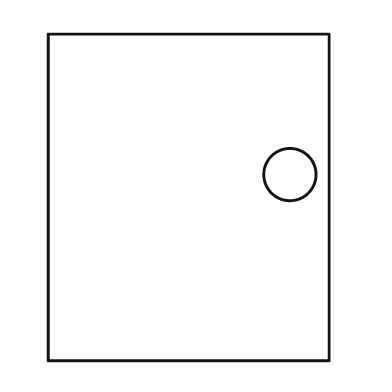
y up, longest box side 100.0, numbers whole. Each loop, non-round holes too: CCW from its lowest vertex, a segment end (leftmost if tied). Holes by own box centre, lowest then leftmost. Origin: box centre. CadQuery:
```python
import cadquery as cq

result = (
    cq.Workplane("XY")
    .moveTo(-43.0, -50.0)
    .lineTo(43.0, -50.0)
    .lineTo(43.0, 50.0)
    .lineTo(-43.0, 50.0)
    .close()
    .moveTo(31.0, 7.0)
    .circle(8.0)
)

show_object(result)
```